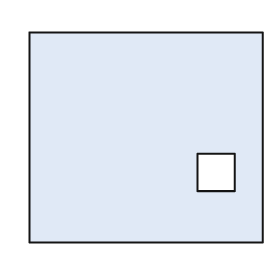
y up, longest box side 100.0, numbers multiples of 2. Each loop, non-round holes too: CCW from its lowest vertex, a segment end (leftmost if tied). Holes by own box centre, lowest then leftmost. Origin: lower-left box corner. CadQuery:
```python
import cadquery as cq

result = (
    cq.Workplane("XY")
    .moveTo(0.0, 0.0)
    .lineTo(100.0, 0.0)
    .lineTo(100.0, 90.0)
    .lineTo(0.0, 90.0)
    .close()
    .moveTo(72.0, 22.0)
    .lineTo(88.0, 22.0)
    .lineTo(88.0, 38.0)
    .lineTo(72.0, 38.0)
    .close()
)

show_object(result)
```